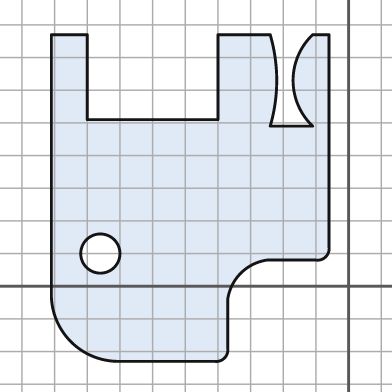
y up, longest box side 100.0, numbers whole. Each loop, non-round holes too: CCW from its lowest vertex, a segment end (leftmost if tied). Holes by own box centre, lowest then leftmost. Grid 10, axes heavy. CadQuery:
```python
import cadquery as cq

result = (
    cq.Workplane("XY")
    .moveTo(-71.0, -23.0)
    .lineTo(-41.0, -23.0)
    .threePointArc((-38.0, -22.0), (-37.0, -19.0))
    .lineTo(-37.0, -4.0)
    .threePointArc((-33.0, 4.0), (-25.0, 8.0))
    .lineTo(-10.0, 8.0)
    .threePointArc((-7.0, 9.0), (-6.0, 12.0))
    .lineTo(-6.0, 77.0)
    .lineTo(-11.0, 77.0)
    .threePointArc((-17.0, 63.0), (-11.0, 49.0))
    .lineTo(-24.0, 49.0)
    .threePointArc((-22.0, 63.0), (-24.0, 77.0))
    .lineTo(-40.0, 77.0)
    .lineTo(-40.0, 51.0)
    .lineTo(-80.0, 51.0)
    .lineTo(-80.0, 77.0)
    .lineTo(-91.0, 77.0)
    .lineTo(-91.0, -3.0)
    .threePointArc((-85.0, -17.0), (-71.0, -23.0))
    .close()
    .moveTo(-76.0, 10.0)
    .circle(6.0)
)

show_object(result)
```